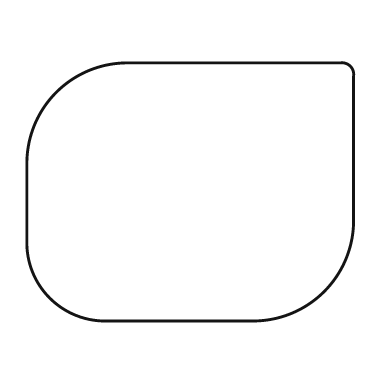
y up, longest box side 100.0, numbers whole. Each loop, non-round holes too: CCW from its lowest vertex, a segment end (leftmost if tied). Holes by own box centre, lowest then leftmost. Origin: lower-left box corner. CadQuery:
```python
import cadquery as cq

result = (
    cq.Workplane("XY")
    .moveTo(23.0, 0.0)
    .lineTo(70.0, 0.0)
    .threePointArc((91.0, 9.0), (100.0, 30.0))
    .lineTo(100.0, 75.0)
    .threePointArc((99.0, 78.0), (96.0, 79.0))
    .lineTo(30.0, 79.0)
    .threePointArc((9.0, 70.0), (0.0, 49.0))
    .lineTo(0.0, 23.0)
    .threePointArc((7.0, 7.0), (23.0, 0.0))
    .close()
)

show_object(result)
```